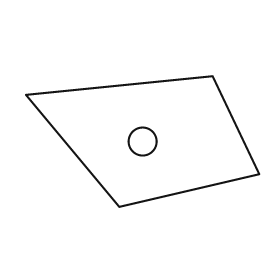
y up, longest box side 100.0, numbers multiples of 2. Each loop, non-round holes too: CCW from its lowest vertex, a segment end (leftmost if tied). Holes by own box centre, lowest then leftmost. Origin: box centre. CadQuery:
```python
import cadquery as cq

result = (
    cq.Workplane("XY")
    .moveTo(-10.0, -28.0)
    .lineTo(50.0, -14.0)
    .lineTo(30.0, 28.0)
    .lineTo(-50.0, 20.0)
    .close()
    .moveTo(0.0, 0.0)
    .circle(6.0)
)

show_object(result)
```